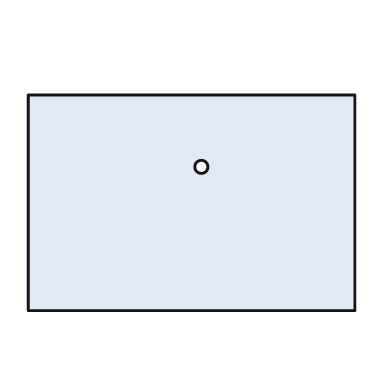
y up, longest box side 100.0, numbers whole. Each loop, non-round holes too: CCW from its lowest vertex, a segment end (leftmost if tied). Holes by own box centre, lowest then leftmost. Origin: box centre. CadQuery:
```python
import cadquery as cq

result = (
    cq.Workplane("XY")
    .moveTo(-50.0, -33.0)
    .lineTo(50.0, -33.0)
    .lineTo(50.0, 33.0)
    .lineTo(-50.0, 33.0)
    .close()
    .moveTo(3.0, 11.0)
    .circle(2.0)
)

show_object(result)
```